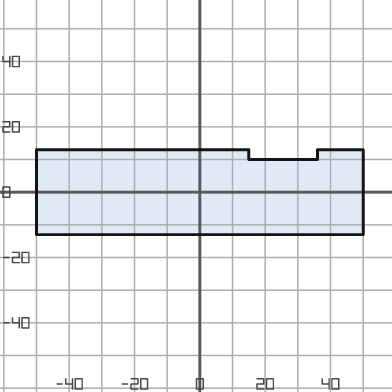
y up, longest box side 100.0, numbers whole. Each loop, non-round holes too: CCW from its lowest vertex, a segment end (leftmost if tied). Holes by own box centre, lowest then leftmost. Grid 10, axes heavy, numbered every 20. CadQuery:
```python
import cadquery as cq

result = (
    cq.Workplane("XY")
    .moveTo(-50.0, -13.0)
    .lineTo(50.0, -13.0)
    .lineTo(50.0, 13.0)
    .lineTo(36.0, 13.0)
    .lineTo(36.0, 10.0)
    .lineTo(15.0, 10.0)
    .lineTo(15.0, 13.0)
    .lineTo(-50.0, 13.0)
    .close()
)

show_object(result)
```